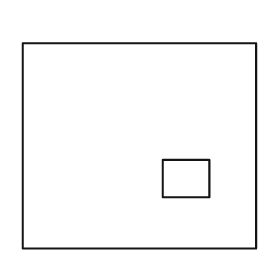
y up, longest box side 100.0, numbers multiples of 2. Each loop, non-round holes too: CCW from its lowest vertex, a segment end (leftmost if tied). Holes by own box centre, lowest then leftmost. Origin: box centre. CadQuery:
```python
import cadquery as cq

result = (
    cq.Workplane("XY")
    .moveTo(-50.0, -44.0)
    .lineTo(50.0, -44.0)
    .lineTo(50.0, 44.0)
    .lineTo(-50.0, 44.0)
    .close()
    .moveTo(10.0, -22.0)
    .lineTo(30.0, -22.0)
    .lineTo(30.0, -6.0)
    .lineTo(10.0, -6.0)
    .close()
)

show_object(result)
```